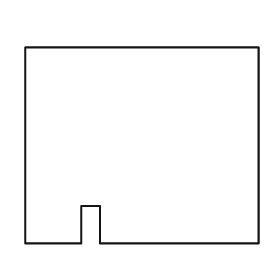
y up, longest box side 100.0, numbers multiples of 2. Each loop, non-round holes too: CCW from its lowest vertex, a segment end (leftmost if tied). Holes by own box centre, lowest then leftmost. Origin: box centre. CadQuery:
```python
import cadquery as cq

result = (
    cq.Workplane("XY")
    .moveTo(-50.0, -42.0)
    .lineTo(-26.0, -42.0)
    .lineTo(-26.0, -26.0)
    .lineTo(-18.0, -26.0)
    .lineTo(-18.0, -42.0)
    .lineTo(50.0, -42.0)
    .lineTo(50.0, 42.0)
    .lineTo(-50.0, 42.0)
    .close()
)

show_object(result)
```